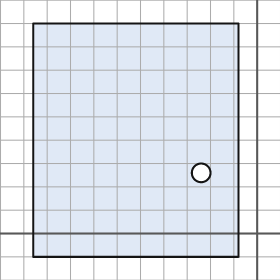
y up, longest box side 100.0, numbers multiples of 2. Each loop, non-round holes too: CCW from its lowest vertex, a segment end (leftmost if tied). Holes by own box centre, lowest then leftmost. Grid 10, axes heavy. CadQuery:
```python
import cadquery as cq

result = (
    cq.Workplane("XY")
    .moveTo(-96.0, -10.0)
    .lineTo(-8.0, -10.0)
    .lineTo(-8.0, 90.0)
    .lineTo(-96.0, 90.0)
    .close()
    .moveTo(-24.0, 26.0)
    .circle(4.0)
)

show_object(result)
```